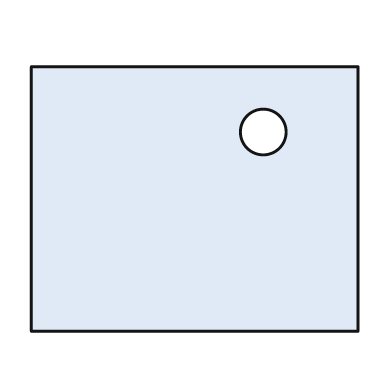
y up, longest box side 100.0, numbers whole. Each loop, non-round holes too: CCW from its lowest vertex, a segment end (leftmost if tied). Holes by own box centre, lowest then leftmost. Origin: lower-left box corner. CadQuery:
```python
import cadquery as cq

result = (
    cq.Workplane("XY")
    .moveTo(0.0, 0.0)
    .lineTo(100.0, 0.0)
    .lineTo(100.0, 81.0)
    .lineTo(0.0, 81.0)
    .close()
    .moveTo(71.0, 61.0)
    .circle(7.0)
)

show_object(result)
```